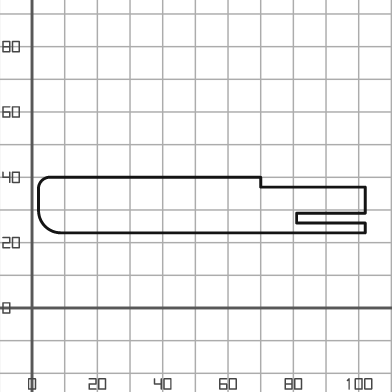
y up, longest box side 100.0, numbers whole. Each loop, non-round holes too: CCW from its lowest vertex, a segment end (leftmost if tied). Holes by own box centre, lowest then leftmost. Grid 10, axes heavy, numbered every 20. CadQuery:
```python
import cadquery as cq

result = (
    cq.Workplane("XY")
    .moveTo(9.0, 23.0)
    .lineTo(102.0, 23.0)
    .lineTo(102.0, 26.0)
    .lineTo(81.0, 26.0)
    .lineTo(81.0, 29.0)
    .lineTo(102.0, 29.0)
    .lineTo(102.0, 37.0)
    .lineTo(70.0, 37.0)
    .lineTo(70.0, 40.0)
    .lineTo(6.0, 40.0)
    .threePointArc((3.0, 39.0), (2.0, 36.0))
    .lineTo(2.0, 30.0)
    .threePointArc((4.0, 25.0), (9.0, 23.0))
    .close()
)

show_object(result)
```